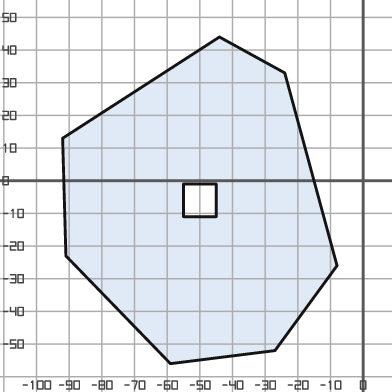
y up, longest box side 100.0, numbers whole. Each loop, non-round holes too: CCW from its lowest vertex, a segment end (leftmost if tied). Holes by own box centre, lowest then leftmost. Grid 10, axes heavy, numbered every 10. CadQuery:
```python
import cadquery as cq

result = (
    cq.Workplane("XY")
    .moveTo(-59.0, -56.0)
    .lineTo(-27.0, -52.0)
    .lineTo(-8.0, -26.0)
    .lineTo(-24.0, 33.0)
    .lineTo(-44.0, 44.0)
    .lineTo(-92.0, 13.0)
    .lineTo(-91.0, -23.0)
    .close()
    .moveTo(-55.0, -11.0)
    .lineTo(-45.0, -11.0)
    .lineTo(-45.0, -1.0)
    .lineTo(-55.0, -1.0)
    .close()
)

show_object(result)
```